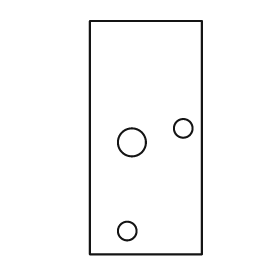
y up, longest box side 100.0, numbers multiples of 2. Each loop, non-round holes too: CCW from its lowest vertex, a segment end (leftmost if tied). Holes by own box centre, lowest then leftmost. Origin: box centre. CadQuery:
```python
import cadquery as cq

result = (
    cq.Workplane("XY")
    .moveTo(-24.0, -50.0)
    .lineTo(24.0, -50.0)
    .lineTo(24.0, 50.0)
    .lineTo(-24.0, 50.0)
    .close()
    .moveTo(-8.0, -40.0)
    .circle(4.0)
    .moveTo(-6.0, -2.0)
    .circle(6.0)
    .moveTo(16.0, 4.0)
    .circle(4.0)
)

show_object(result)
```